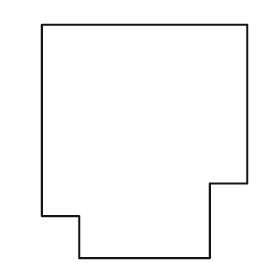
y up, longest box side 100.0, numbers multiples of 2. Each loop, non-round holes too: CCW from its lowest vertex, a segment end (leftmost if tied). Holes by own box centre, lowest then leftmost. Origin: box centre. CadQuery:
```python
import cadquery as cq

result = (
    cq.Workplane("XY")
    .moveTo(-28.0, -50.0)
    .lineTo(28.0, -50.0)
    .lineTo(28.0, -18.0)
    .lineTo(44.0, -18.0)
    .lineTo(44.0, 50.0)
    .lineTo(-44.0, 50.0)
    .lineTo(-44.0, -32.0)
    .lineTo(-28.0, -32.0)
    .close()
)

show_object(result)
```